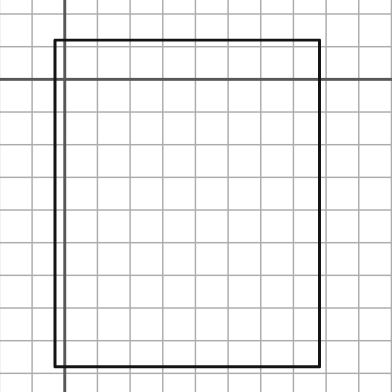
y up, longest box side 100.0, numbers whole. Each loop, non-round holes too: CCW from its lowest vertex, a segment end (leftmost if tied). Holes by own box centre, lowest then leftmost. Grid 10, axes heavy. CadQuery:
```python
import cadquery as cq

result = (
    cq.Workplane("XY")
    .moveTo(-3.0, -88.0)
    .lineTo(78.0, -88.0)
    .lineTo(78.0, 12.0)
    .lineTo(-3.0, 12.0)
    .close()
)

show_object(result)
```